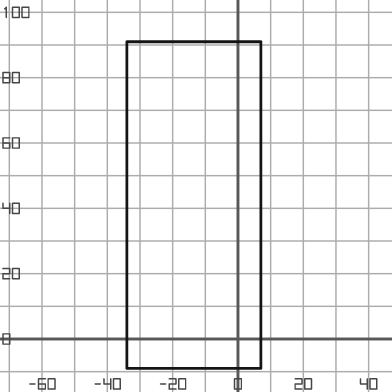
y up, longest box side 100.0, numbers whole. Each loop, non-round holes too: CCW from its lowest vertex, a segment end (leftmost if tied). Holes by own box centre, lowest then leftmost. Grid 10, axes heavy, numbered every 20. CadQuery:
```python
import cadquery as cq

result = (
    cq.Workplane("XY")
    .moveTo(-34.0, -9.0)
    .lineTo(7.0, -9.0)
    .lineTo(7.0, 91.0)
    .lineTo(-34.0, 91.0)
    .close()
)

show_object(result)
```